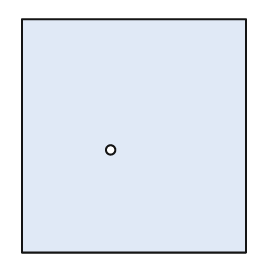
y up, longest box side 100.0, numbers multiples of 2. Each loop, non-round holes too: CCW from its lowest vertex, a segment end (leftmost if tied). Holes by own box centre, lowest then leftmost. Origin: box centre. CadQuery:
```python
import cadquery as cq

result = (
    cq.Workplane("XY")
    .moveTo(-48.0, -50.0)
    .lineTo(48.0, -50.0)
    .lineTo(48.0, 50.0)
    .lineTo(-48.0, 50.0)
    .close()
    .moveTo(-10.0, -6.0)
    .circle(2.0)
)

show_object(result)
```